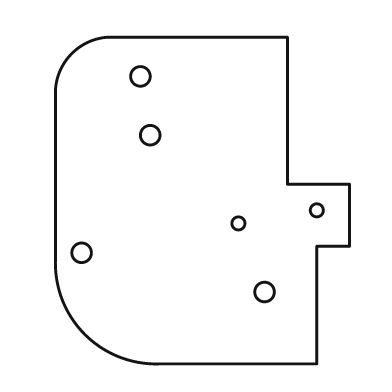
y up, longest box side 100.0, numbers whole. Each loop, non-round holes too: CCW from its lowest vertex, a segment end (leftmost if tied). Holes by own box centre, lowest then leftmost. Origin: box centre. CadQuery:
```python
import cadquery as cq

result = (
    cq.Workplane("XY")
    .moveTo(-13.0, -50.0)
    .lineTo(35.0, -50.0)
    .lineTo(35.0, -14.0)
    .lineTo(45.0, -14.0)
    .lineTo(45.0, 5.0)
    .lineTo(26.0, 5.0)
    .lineTo(26.0, 50.0)
    .lineTo(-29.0, 50.0)
    .threePointArc((-40.0, 45.0), (-45.0, 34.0))
    .lineTo(-45.0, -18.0)
    .threePointArc((-36.0, -41.0), (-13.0, -50.0))
    .close()
    .moveTo(19.0, -28.0)
    .circle(3.0)
    .moveTo(-37.0, -16.0)
    .circle(3.0)
    .moveTo(11.0, -7.0)
    .circle(2.0)
    .moveTo(35.0, -3.0)
    .circle(2.0)
    .moveTo(-16.0, 20.0)
    .circle(3.0)
    .moveTo(-19.0, 38.0)
    .circle(3.0)
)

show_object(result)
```